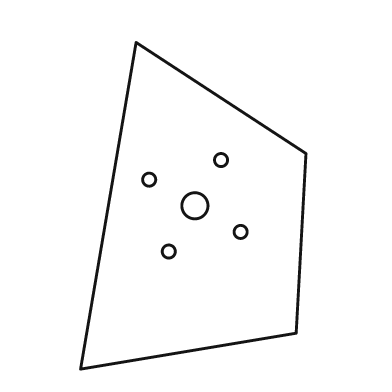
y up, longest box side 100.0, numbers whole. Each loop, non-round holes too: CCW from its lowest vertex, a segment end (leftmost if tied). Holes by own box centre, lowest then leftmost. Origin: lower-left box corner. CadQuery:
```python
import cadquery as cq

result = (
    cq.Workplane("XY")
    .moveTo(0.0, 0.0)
    .lineTo(66.0, 11.0)
    .lineTo(69.0, 66.0)
    .lineTo(17.0, 100.0)
    .close()
    .moveTo(27.0, 36.0)
    .circle(2.0)
    .moveTo(49.0, 42.0)
    .circle(2.0)
    .moveTo(35.0, 50.0)
    .circle(4.0)
    .moveTo(21.0, 58.0)
    .circle(2.0)
    .moveTo(43.0, 64.0)
    .circle(2.0)
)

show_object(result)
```